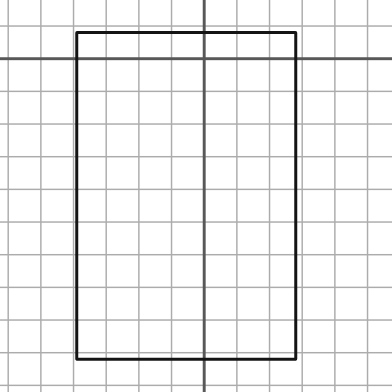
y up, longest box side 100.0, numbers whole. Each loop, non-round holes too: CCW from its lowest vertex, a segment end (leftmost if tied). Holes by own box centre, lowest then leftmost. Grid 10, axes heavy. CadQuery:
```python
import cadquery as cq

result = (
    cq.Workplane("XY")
    .moveTo(-39.0, -92.0)
    .lineTo(28.0, -92.0)
    .lineTo(28.0, 8.0)
    .lineTo(-39.0, 8.0)
    .close()
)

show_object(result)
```